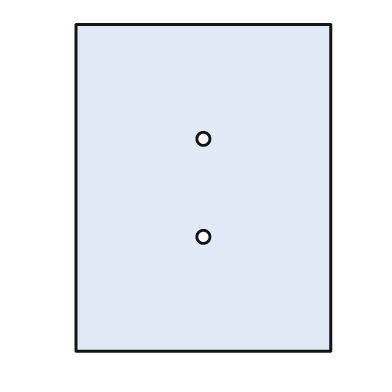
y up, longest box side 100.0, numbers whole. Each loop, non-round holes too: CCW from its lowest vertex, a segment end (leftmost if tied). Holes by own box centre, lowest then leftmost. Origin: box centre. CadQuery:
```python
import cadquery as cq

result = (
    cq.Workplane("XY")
    .moveTo(-39.0, -50.0)
    .lineTo(39.0, -50.0)
    .lineTo(39.0, 50.0)
    .lineTo(-39.0, 50.0)
    .close()
    .moveTo(0.0, -15.0)
    .circle(2.0)
    .moveTo(0.0, 15.0)
    .circle(2.0)
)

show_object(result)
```